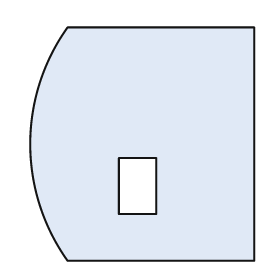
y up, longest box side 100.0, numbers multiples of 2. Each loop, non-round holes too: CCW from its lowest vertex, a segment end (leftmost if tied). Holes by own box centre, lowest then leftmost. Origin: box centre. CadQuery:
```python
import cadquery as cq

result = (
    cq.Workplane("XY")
    .moveTo(-32.0, -50.0)
    .lineTo(48.0, -50.0)
    .lineTo(48.0, 50.0)
    .lineTo(-32.0, 50.0)
    .threePointArc((-48.0, 0.0), (-32.0, -50.0))
    .close()
    .moveTo(-10.0, -30.0)
    .lineTo(6.0, -30.0)
    .lineTo(6.0, -6.0)
    .lineTo(-10.0, -6.0)
    .close()
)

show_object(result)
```